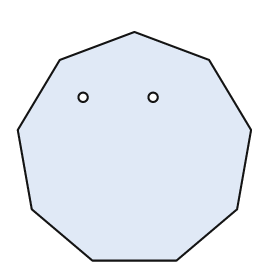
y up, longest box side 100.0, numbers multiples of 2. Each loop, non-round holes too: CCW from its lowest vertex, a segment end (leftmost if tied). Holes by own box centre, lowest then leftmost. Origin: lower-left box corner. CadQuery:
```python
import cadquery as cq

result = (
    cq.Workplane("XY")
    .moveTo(32.0, 0.0)
    .lineTo(68.0, 0.0)
    .lineTo(94.0, 22.0)
    .lineTo(100.0, 56.0)
    .lineTo(82.0, 86.0)
    .lineTo(50.0, 98.0)
    .lineTo(18.0, 86.0)
    .lineTo(0.0, 56.0)
    .lineTo(6.0, 22.0)
    .close()
    .moveTo(28.0, 70.0)
    .circle(2.0)
    .moveTo(58.0, 70.0)
    .circle(2.0)
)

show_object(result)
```